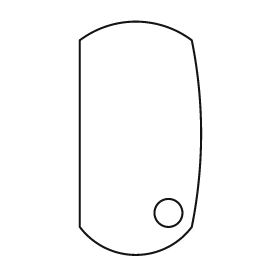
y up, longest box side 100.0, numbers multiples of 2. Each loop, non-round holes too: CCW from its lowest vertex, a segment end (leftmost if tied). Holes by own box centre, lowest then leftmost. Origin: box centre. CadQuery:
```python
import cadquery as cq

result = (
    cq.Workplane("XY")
    .moveTo(-26.0, -38.0)
    .threePointArc((-2.0, -50.0), (22.0, -38.0))
    .threePointArc((26.0, 2.0), (22.0, 42.0))
    .threePointArc((-2.0, 50.0), (-26.0, 42.0))
    .close()
    .moveTo(12.0, -32.0)
    .circle(6.0)
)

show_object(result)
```